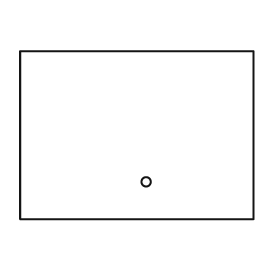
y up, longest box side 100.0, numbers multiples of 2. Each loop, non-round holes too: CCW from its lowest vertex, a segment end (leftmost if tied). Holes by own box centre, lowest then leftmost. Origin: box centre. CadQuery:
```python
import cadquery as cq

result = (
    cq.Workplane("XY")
    .moveTo(-50.0, -36.0)
    .lineTo(50.0, -36.0)
    .lineTo(50.0, 36.0)
    .lineTo(-50.0, 36.0)
    .close()
    .moveTo(4.0, -20.0)
    .circle(2.0)
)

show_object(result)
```